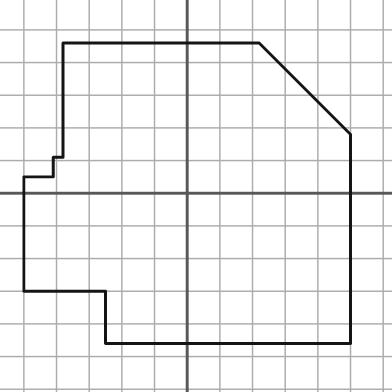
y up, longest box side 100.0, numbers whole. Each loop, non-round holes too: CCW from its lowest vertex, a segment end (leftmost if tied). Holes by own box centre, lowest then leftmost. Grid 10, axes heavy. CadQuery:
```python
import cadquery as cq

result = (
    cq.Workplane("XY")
    .moveTo(-25.0, -46.0)
    .lineTo(50.0, -46.0)
    .lineTo(50.0, 18.0)
    .lineTo(22.0, 46.0)
    .lineTo(-38.0, 46.0)
    .lineTo(-38.0, 11.0)
    .lineTo(-41.0, 11.0)
    .lineTo(-41.0, 5.0)
    .lineTo(-50.0, 5.0)
    .lineTo(-50.0, -30.0)
    .lineTo(-25.0, -30.0)
    .close()
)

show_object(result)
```